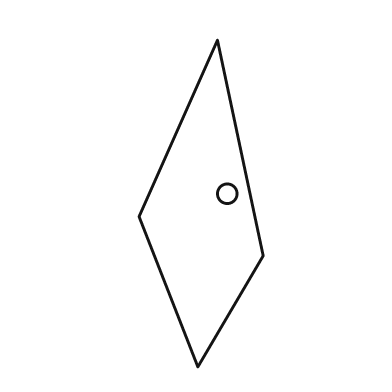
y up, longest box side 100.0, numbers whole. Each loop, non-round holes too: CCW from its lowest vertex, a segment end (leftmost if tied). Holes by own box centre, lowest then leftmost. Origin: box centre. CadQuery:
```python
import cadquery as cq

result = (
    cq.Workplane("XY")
    .moveTo(-1.0, -50.0)
    .lineTo(19.0, -16.0)
    .lineTo(5.0, 50.0)
    .lineTo(-19.0, -4.0)
    .close()
    .moveTo(8.0, 3.0)
    .circle(3.0)
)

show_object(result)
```